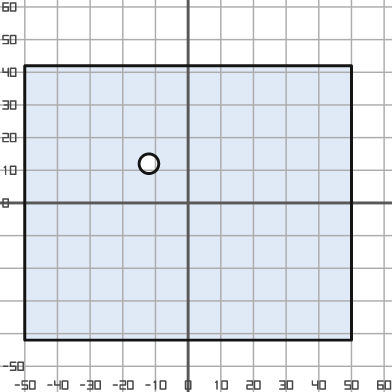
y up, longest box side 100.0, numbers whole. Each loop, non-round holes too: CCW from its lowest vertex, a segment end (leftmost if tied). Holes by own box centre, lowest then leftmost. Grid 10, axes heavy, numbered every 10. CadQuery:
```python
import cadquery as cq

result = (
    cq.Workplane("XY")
    .moveTo(-50.0, -42.0)
    .lineTo(50.0, -42.0)
    .lineTo(50.0, 42.0)
    .lineTo(-50.0, 42.0)
    .close()
    .moveTo(-12.0, 12.0)
    .circle(3.0)
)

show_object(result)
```